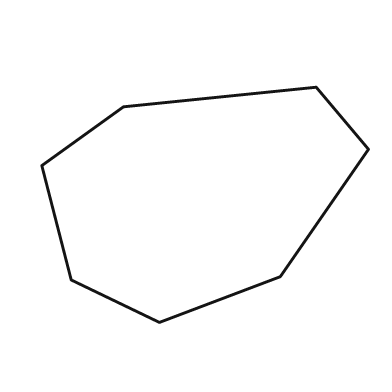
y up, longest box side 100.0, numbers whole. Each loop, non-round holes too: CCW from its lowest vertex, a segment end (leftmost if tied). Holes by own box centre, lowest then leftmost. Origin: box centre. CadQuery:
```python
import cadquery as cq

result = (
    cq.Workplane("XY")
    .moveTo(-14.0, -36.0)
    .lineTo(23.0, -22.0)
    .lineTo(50.0, 17.0)
    .lineTo(34.0, 36.0)
    .lineTo(-25.0, 30.0)
    .lineTo(-50.0, 12.0)
    .lineTo(-41.0, -23.0)
    .close()
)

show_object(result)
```